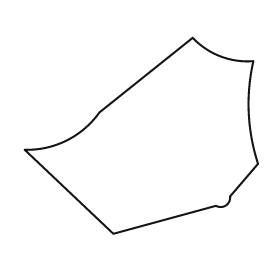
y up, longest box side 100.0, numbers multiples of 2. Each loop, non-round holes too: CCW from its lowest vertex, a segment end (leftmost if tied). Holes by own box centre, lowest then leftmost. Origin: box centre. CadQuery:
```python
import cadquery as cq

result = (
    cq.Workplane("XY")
    .moveTo(-12.0, -42.0)
    .lineTo(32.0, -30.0)
    .threePointArc((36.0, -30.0), (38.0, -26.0))
    .lineTo(50.0, -12.0)
    .threePointArc((46.0, 10.0), (48.0, 32.0))
    .threePointArc((34.0, 34.0), (22.0, 42.0))
    .lineTo(-18.0, 10.0)
    .threePointArc((-32.0, -2.0), (-50.0, -6.0))
    .close()
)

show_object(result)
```